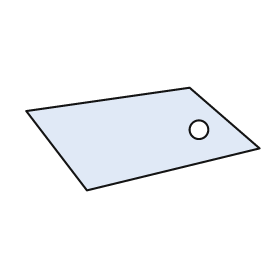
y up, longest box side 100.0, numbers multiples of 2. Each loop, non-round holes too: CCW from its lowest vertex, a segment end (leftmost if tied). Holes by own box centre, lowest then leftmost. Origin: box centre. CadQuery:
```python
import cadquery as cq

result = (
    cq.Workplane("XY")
    .moveTo(-24.0, -22.0)
    .lineTo(50.0, -4.0)
    .lineTo(20.0, 22.0)
    .lineTo(-50.0, 12.0)
    .close()
    .moveTo(24.0, 4.0)
    .circle(4.0)
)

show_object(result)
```